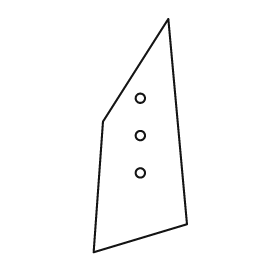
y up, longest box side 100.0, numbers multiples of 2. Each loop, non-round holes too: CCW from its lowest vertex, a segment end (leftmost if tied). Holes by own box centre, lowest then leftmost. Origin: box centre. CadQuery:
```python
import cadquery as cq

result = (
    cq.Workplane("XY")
    .moveTo(-20.0, -50.0)
    .lineTo(20.0, -38.0)
    .lineTo(12.0, 50.0)
    .lineTo(-16.0, 6.0)
    .close()
    .moveTo(0.0, -16.0)
    .circle(2.0)
    .moveTo(0.0, 0.0)
    .circle(2.0)
    .moveTo(0.0, 16.0)
    .circle(2.0)
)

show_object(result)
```